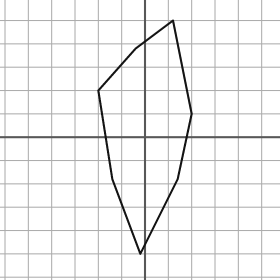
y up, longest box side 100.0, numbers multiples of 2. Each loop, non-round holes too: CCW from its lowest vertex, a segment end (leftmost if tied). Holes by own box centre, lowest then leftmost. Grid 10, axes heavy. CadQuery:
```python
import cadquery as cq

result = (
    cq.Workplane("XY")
    .moveTo(-2.0, -50.0)
    .lineTo(14.0, -18.0)
    .lineTo(20.0, 10.0)
    .lineTo(12.0, 50.0)
    .lineTo(-4.0, 38.0)
    .lineTo(-20.0, 20.0)
    .lineTo(-14.0, -18.0)
    .close()
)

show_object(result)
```